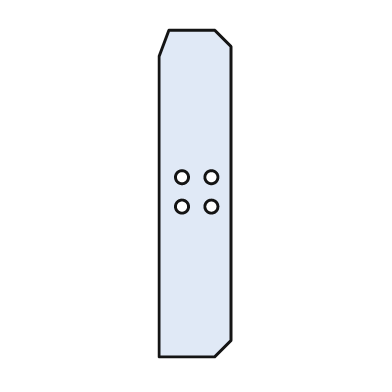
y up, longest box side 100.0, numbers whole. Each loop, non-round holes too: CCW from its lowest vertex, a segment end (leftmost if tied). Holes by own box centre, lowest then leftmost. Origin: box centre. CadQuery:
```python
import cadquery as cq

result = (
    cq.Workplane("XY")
    .moveTo(-11.0, -50.0)
    .lineTo(6.0, -50.0)
    .lineTo(11.0, -45.0)
    .lineTo(11.0, 45.0)
    .lineTo(6.0, 50.0)
    .lineTo(-8.0, 50.0)
    .lineTo(-11.0, 42.0)
    .close()
    .moveTo(-4.0, -4.0)
    .circle(2.0)
    .moveTo(5.0, -4.0)
    .circle(2.0)
    .moveTo(-4.0, 5.0)
    .circle(2.0)
    .moveTo(5.0, 5.0)
    .circle(2.0)
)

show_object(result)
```